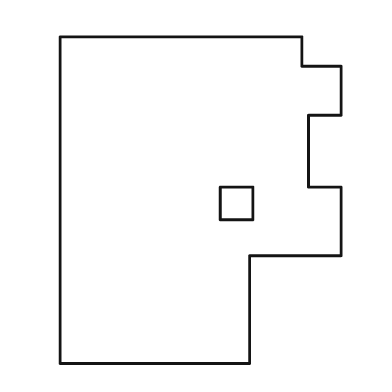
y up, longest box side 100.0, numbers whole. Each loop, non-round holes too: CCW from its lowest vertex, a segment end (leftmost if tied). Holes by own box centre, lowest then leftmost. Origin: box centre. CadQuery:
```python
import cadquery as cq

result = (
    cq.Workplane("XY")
    .moveTo(-43.0, -50.0)
    .lineTo(15.0, -50.0)
    .lineTo(15.0, -17.0)
    .lineTo(43.0, -17.0)
    .lineTo(43.0, 4.0)
    .lineTo(33.0, 4.0)
    .lineTo(33.0, 26.0)
    .lineTo(43.0, 26.0)
    .lineTo(43.0, 41.0)
    .lineTo(31.0, 41.0)
    .lineTo(31.0, 50.0)
    .lineTo(-43.0, 50.0)
    .close()
    .moveTo(6.0, -6.0)
    .lineTo(16.0, -6.0)
    .lineTo(16.0, 4.0)
    .lineTo(6.0, 4.0)
    .close()
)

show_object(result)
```